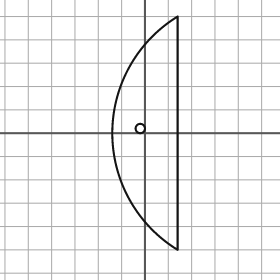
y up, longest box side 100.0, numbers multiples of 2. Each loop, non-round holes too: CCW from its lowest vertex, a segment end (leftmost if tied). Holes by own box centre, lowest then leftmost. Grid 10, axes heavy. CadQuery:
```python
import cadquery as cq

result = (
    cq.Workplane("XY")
    .moveTo(14.0, -50.0)
    .lineTo(14.0, 50.0)
    .threePointArc((-14.0, 0.0), (14.0, -50.0))
    .close()
    .moveTo(-2.0, 2.0)
    .circle(2.0)
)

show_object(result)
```